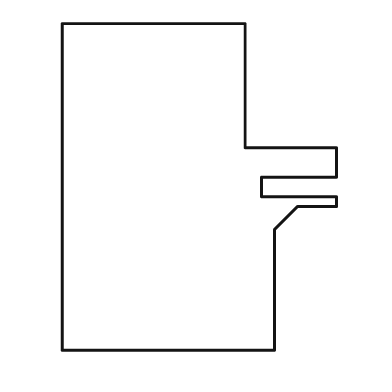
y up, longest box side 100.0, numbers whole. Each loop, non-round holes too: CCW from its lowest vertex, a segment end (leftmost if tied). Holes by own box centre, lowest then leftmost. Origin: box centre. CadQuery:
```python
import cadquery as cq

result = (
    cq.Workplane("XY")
    .moveTo(-42.0, -50.0)
    .lineTo(23.0, -50.0)
    .lineTo(23.0, -13.0)
    .lineTo(30.0, -6.0)
    .lineTo(42.0, -6.0)
    .lineTo(42.0, -3.0)
    .lineTo(19.0, -3.0)
    .lineTo(19.0, 3.0)
    .lineTo(42.0, 3.0)
    .lineTo(42.0, 12.0)
    .lineTo(14.0, 12.0)
    .lineTo(14.0, 50.0)
    .lineTo(-42.0, 50.0)
    .close()
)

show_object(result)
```